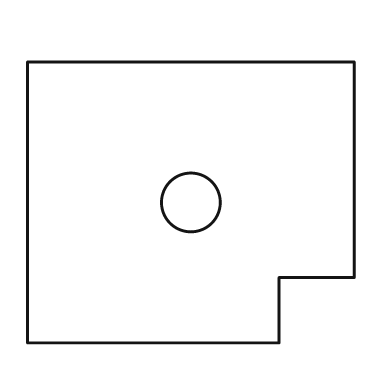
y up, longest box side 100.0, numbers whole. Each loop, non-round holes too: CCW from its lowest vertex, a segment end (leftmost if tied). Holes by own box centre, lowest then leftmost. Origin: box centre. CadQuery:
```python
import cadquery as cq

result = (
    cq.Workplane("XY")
    .moveTo(-50.0, -43.0)
    .lineTo(27.0, -43.0)
    .lineTo(27.0, -23.0)
    .lineTo(50.0, -23.0)
    .lineTo(50.0, 43.0)
    .lineTo(-50.0, 43.0)
    .close()
    .moveTo(0.0, 0.0)
    .circle(9.0)
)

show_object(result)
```